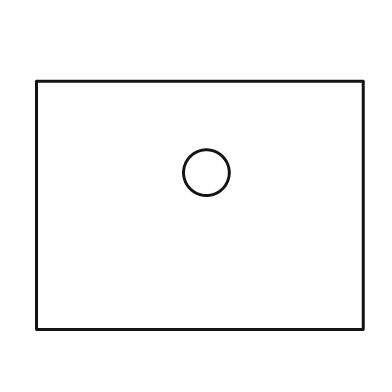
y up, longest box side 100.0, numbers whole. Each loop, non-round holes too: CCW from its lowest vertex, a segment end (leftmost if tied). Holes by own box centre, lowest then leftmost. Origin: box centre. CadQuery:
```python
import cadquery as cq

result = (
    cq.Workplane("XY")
    .moveTo(-50.0, -38.0)
    .lineTo(50.0, -38.0)
    .lineTo(50.0, 38.0)
    .lineTo(-50.0, 38.0)
    .close()
    .moveTo(2.0, 10.0)
    .circle(7.0)
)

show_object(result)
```